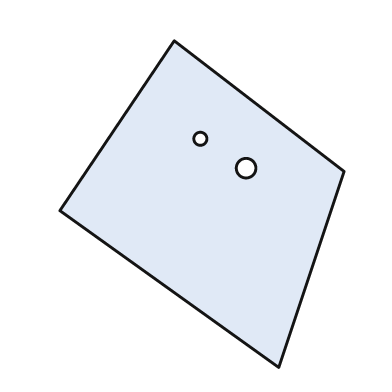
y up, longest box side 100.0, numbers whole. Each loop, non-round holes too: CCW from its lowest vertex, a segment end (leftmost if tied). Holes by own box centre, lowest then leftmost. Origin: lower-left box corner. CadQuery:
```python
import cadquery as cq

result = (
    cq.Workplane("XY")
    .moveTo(67.0, 0.0)
    .lineTo(87.0, 60.0)
    .lineTo(35.0, 100.0)
    .lineTo(0.0, 48.0)
    .close()
    .moveTo(57.0, 61.0)
    .circle(3.0)
    .moveTo(43.0, 70.0)
    .circle(2.0)
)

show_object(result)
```